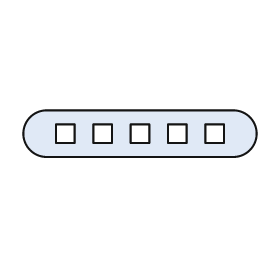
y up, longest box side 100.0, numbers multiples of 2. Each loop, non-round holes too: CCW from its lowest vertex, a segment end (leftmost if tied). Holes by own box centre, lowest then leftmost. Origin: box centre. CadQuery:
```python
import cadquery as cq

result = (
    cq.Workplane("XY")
    .moveTo(-40.0, -10.0)
    .lineTo(40.0, -10.0)
    .threePointArc((50.0, 0.0), (40.0, 10.0))
    .lineTo(-40.0, 10.0)
    .threePointArc((-50.0, 0.0), (-40.0, -10.0))
    .close()
    .moveTo(-36.0, -4.0)
    .lineTo(-28.0, -4.0)
    .lineTo(-28.0, 4.0)
    .lineTo(-36.0, 4.0)
    .close()
    .moveTo(-20.0, -4.0)
    .lineTo(-12.0, -4.0)
    .lineTo(-12.0, 4.0)
    .lineTo(-20.0, 4.0)
    .close()
    .moveTo(-4.0, -4.0)
    .lineTo(4.0, -4.0)
    .lineTo(4.0, 4.0)
    .lineTo(-4.0, 4.0)
    .close()
    .moveTo(12.0, -4.0)
    .lineTo(20.0, -4.0)
    .lineTo(20.0, 4.0)
    .lineTo(12.0, 4.0)
    .close()
    .moveTo(28.0, -4.0)
    .lineTo(36.0, -4.0)
    .lineTo(36.0, 4.0)
    .lineTo(28.0, 4.0)
    .close()
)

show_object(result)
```